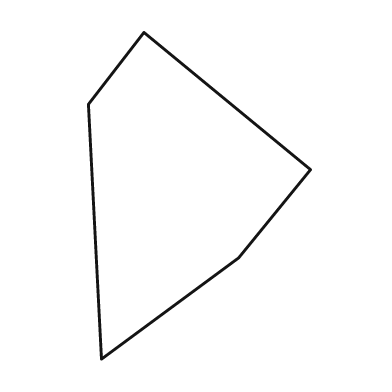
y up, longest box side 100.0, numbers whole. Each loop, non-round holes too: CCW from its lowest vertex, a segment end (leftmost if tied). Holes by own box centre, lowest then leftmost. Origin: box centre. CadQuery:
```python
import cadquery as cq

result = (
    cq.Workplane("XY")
    .moveTo(-30.0, -50.0)
    .lineTo(12.0, -19.0)
    .lineTo(34.0, 8.0)
    .lineTo(-17.0, 50.0)
    .lineTo(-34.0, 28.0)
    .close()
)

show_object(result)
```